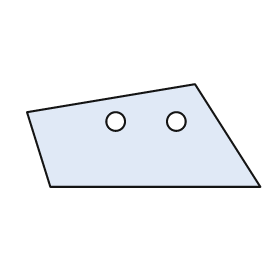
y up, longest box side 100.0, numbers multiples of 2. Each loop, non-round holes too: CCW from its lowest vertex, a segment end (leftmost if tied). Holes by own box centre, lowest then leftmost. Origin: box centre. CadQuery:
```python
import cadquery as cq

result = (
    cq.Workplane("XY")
    .moveTo(-40.0, -22.0)
    .lineTo(50.0, -22.0)
    .lineTo(22.0, 22.0)
    .lineTo(-50.0, 10.0)
    .close()
    .moveTo(-12.0, 6.0)
    .circle(4.0)
    .moveTo(14.0, 6.0)
    .circle(4.0)
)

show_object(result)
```